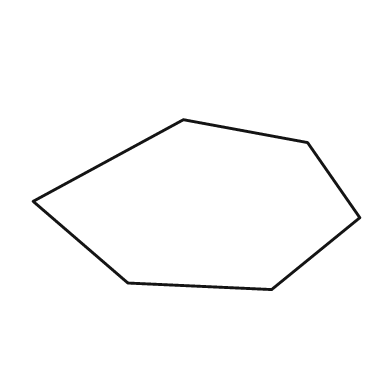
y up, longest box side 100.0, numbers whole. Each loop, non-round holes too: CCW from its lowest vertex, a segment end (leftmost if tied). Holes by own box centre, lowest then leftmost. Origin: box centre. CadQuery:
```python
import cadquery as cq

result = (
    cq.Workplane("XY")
    .moveTo(23.0, -26.0)
    .lineTo(50.0, -4.0)
    .lineTo(34.0, 19.0)
    .lineTo(-4.0, 26.0)
    .lineTo(-50.0, 1.0)
    .lineTo(-21.0, -24.0)
    .close()
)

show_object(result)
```